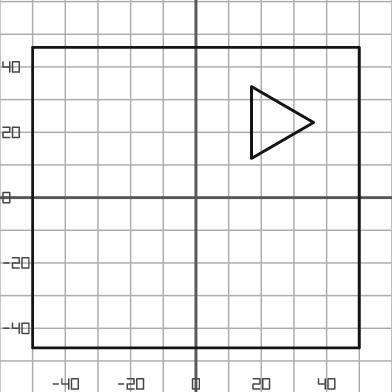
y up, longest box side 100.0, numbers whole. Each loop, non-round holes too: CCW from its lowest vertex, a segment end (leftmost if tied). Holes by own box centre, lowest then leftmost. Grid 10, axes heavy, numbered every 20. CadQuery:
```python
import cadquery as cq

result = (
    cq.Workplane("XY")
    .moveTo(-50.0, -46.0)
    .lineTo(50.0, -46.0)
    .lineTo(50.0, 46.0)
    .lineTo(-50.0, 46.0)
    .close()
    .moveTo(17.0, 12.0)
    .lineTo(36.0, 23.0)
    .lineTo(17.0, 34.0)
    .close()
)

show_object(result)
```